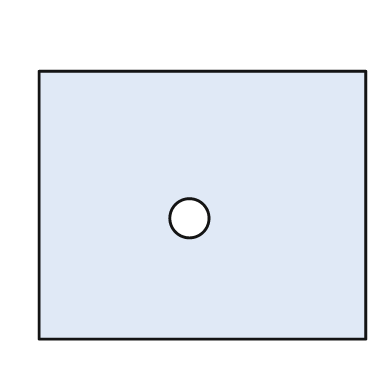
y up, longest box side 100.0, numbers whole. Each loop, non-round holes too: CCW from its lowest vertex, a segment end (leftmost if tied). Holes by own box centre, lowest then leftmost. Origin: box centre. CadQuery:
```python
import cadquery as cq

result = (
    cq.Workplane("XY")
    .moveTo(-50.0, -41.0)
    .lineTo(50.0, -41.0)
    .lineTo(50.0, 41.0)
    .lineTo(-50.0, 41.0)
    .close()
    .moveTo(-4.0, -4.0)
    .circle(6.0)
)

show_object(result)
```